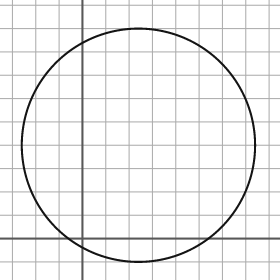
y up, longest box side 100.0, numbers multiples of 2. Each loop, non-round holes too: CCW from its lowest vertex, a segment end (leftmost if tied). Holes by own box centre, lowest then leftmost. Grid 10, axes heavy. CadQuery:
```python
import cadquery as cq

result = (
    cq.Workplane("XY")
    .moveTo(24.0, 40.0)
    .circle(50.0)
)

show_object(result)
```